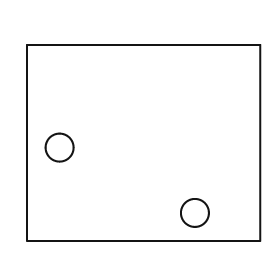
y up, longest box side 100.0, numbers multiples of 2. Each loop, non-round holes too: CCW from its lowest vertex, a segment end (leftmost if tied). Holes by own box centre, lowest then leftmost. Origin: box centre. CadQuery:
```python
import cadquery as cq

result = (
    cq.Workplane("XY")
    .moveTo(-50.0, -42.0)
    .lineTo(50.0, -42.0)
    .lineTo(50.0, 42.0)
    .lineTo(-50.0, 42.0)
    .close()
    .moveTo(22.0, -30.0)
    .circle(6.0)
    .moveTo(-36.0, -2.0)
    .circle(6.0)
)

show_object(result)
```